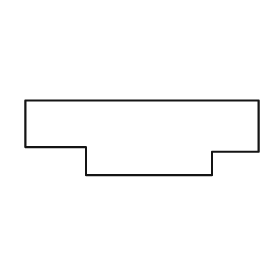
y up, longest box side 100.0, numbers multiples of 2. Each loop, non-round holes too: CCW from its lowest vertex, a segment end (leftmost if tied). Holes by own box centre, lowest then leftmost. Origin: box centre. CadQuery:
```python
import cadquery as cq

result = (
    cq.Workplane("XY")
    .moveTo(-24.0, -16.0)
    .lineTo(30.0, -16.0)
    .lineTo(30.0, -6.0)
    .lineTo(50.0, -6.0)
    .lineTo(50.0, 16.0)
    .lineTo(-50.0, 16.0)
    .lineTo(-50.0, -4.0)
    .lineTo(-24.0, -4.0)
    .close()
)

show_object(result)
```